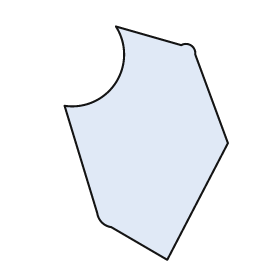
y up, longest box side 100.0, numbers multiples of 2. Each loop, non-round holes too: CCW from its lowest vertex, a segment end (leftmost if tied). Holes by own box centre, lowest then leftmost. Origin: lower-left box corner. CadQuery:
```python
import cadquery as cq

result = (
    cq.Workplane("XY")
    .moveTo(44.0, 0.0)
    .lineTo(70.0, 50.0)
    .lineTo(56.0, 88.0)
    .threePointArc((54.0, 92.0), (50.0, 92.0))
    .lineTo(22.0, 100.0)
    .threePointArc((22.0, 76.0), (0.0, 66.0))
    .lineTo(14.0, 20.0)
    .threePointArc((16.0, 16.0), (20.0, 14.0))
    .close()
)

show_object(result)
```